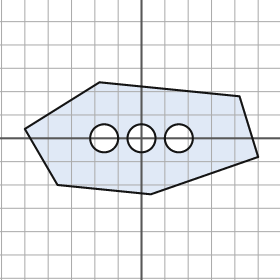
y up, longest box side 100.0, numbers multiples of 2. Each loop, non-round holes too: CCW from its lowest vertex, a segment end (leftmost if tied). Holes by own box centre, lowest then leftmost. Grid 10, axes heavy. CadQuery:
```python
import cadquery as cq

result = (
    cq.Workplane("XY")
    .moveTo(4.0, -24.0)
    .lineTo(50.0, -8.0)
    .lineTo(42.0, 18.0)
    .lineTo(-18.0, 24.0)
    .lineTo(-50.0, 4.0)
    .lineTo(-36.0, -20.0)
    .close()
    .moveTo(-16.0, 0.0)
    .circle(6.0)
    .moveTo(0.0, 0.0)
    .circle(6.0)
    .moveTo(16.0, 0.0)
    .circle(6.0)
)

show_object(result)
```